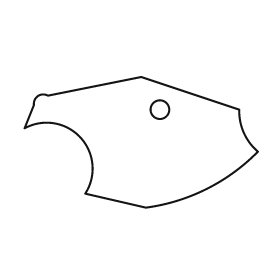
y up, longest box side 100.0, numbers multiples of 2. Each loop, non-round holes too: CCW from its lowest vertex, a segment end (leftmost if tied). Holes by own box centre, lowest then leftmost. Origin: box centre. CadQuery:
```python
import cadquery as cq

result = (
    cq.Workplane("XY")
    .moveTo(2.0, -28.0)
    .threePointArc((28.0, -20.0), (50.0, -4.0))
    .threePointArc((44.0, 4.0), (42.0, 14.0))
    .lineTo(0.0, 28.0)
    .lineTo(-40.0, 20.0)
    .threePointArc((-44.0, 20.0), (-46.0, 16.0))
    .lineTo(-50.0, 6.0)
    .threePointArc((-26.0, 2.0), (-24.0, -22.0))
    .close()
    .moveTo(8.0, 14.0)
    .circle(4.0)
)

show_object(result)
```